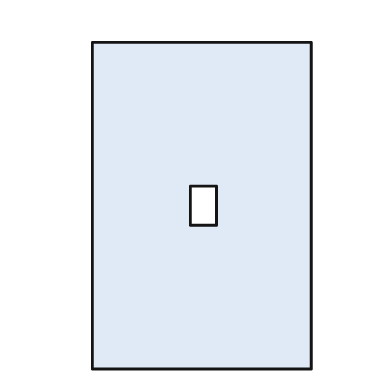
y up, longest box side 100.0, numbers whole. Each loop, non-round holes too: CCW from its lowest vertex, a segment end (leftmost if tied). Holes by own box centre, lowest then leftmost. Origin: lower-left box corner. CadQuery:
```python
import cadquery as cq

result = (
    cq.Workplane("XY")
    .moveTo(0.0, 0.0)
    .lineTo(67.0, 0.0)
    .lineTo(67.0, 100.0)
    .lineTo(0.0, 100.0)
    .close()
    .moveTo(30.0, 44.0)
    .lineTo(38.0, 44.0)
    .lineTo(38.0, 56.0)
    .lineTo(30.0, 56.0)
    .close()
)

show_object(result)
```